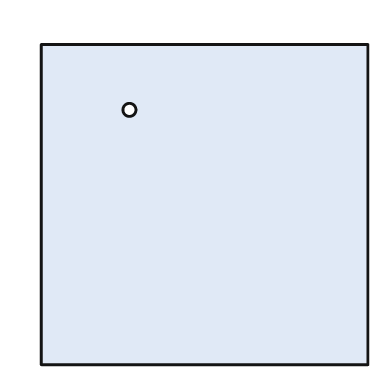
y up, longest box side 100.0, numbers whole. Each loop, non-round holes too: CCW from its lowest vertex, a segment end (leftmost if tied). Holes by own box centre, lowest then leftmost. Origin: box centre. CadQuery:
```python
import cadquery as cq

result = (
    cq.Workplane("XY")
    .moveTo(-50.0, -49.0)
    .lineTo(50.0, -49.0)
    .lineTo(50.0, 49.0)
    .lineTo(-50.0, 49.0)
    .close()
    .moveTo(-23.0, 29.0)
    .circle(2.0)
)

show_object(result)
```